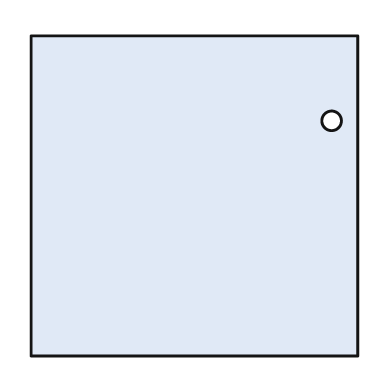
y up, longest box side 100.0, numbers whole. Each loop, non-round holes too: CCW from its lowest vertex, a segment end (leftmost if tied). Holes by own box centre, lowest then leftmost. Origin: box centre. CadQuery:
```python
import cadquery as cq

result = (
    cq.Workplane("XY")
    .moveTo(-50.0, -49.0)
    .lineTo(50.0, -49.0)
    .lineTo(50.0, 49.0)
    .lineTo(-50.0, 49.0)
    .close()
    .moveTo(42.0, 23.0)
    .circle(3.0)
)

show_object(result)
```